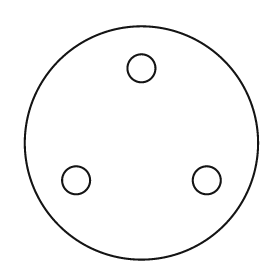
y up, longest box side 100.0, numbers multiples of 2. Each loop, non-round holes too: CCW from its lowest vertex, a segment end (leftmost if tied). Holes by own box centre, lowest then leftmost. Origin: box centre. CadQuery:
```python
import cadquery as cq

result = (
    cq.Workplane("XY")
    .moveTo(0.0, 0.0)
    .circle(50.0)
    .moveTo(-28.0, -16.0)
    .circle(6.0)
    .moveTo(28.0, -16.0)
    .circle(6.0)
    .moveTo(0.0, 32.0)
    .circle(6.0)
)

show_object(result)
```